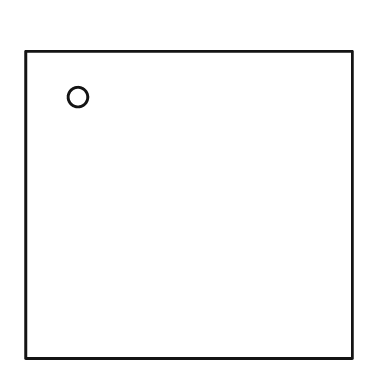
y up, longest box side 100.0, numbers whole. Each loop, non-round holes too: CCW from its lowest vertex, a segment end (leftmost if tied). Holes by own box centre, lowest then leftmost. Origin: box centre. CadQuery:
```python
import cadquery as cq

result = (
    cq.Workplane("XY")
    .moveTo(-50.0, -47.0)
    .lineTo(50.0, -47.0)
    .lineTo(50.0, 47.0)
    .lineTo(-50.0, 47.0)
    .close()
    .moveTo(-34.0, 33.0)
    .circle(3.0)
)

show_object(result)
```